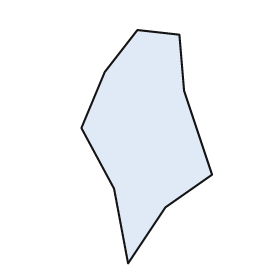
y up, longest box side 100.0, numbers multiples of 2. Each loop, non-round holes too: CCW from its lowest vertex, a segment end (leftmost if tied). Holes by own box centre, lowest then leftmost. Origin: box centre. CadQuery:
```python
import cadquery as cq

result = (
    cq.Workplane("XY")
    .moveTo(-8.0, -50.0)
    .lineTo(8.0, -26.0)
    .lineTo(28.0, -12.0)
    .lineTo(16.0, 24.0)
    .lineTo(14.0, 48.0)
    .lineTo(-4.0, 50.0)
    .lineTo(-18.0, 32.0)
    .lineTo(-28.0, 8.0)
    .lineTo(-14.0, -18.0)
    .close()
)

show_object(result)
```